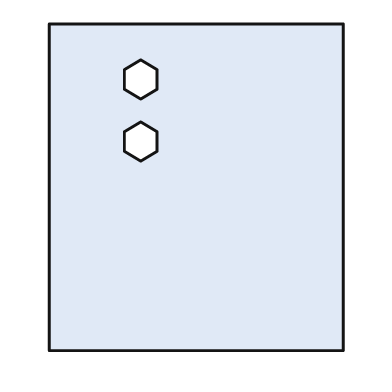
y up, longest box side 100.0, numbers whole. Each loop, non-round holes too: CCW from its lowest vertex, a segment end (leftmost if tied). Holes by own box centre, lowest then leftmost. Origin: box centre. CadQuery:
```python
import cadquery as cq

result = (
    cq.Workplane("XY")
    .moveTo(-45.0, -50.0)
    .lineTo(45.0, -50.0)
    .lineTo(45.0, 50.0)
    .lineTo(-45.0, 50.0)
    .close()
    .moveTo(-17.0, 8.0)
    .lineTo(-12.0, 11.0)
    .lineTo(-12.0, 17.0)
    .lineTo(-17.0, 20.0)
    .lineTo(-22.0, 17.0)
    .lineTo(-22.0, 11.0)
    .close()
    .moveTo(-17.0, 27.0)
    .lineTo(-12.0, 30.0)
    .lineTo(-12.0, 36.0)
    .lineTo(-17.0, 39.0)
    .lineTo(-22.0, 36.0)
    .lineTo(-22.0, 30.0)
    .close()
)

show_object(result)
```